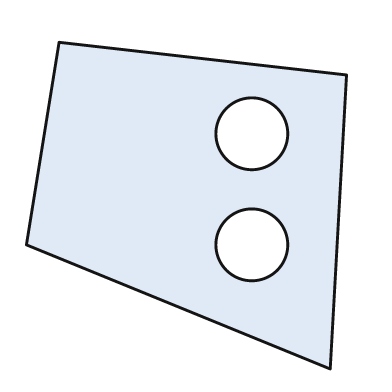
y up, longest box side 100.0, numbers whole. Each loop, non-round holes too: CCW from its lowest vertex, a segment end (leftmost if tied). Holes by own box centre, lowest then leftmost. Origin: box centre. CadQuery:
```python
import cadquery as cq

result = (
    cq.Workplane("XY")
    .moveTo(44.0, -50.0)
    .lineTo(49.0, 40.0)
    .lineTo(-39.0, 50.0)
    .lineTo(-49.0, -12.0)
    .close()
    .moveTo(20.0, -12.0)
    .circle(11.0)
    .moveTo(20.0, 22.0)
    .circle(11.0)
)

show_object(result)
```